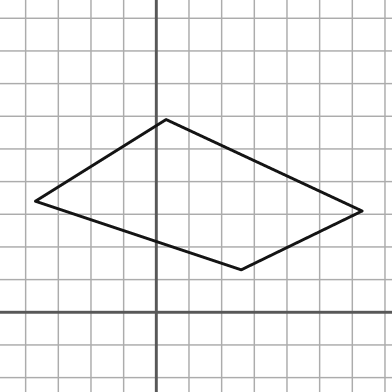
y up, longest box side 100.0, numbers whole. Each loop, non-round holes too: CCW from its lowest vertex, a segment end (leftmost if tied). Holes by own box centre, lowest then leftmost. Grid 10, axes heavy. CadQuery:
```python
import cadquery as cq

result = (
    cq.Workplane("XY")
    .moveTo(26.0, 13.0)
    .lineTo(63.0, 31.0)
    .lineTo(3.0, 59.0)
    .lineTo(-37.0, 34.0)
    .close()
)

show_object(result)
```